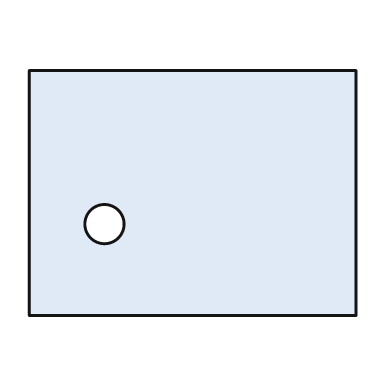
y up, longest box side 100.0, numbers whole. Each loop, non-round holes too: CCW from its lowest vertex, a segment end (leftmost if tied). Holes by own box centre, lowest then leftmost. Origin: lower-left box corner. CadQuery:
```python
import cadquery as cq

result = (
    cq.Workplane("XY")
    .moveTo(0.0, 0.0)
    .lineTo(100.0, 0.0)
    .lineTo(100.0, 75.0)
    .lineTo(0.0, 75.0)
    .close()
    .moveTo(23.0, 28.0)
    .circle(6.0)
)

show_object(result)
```